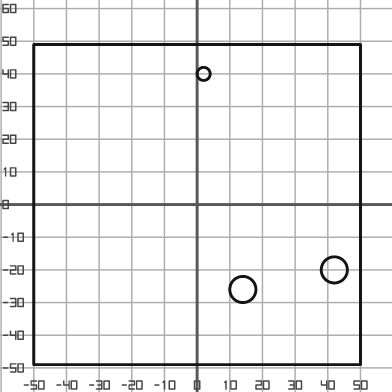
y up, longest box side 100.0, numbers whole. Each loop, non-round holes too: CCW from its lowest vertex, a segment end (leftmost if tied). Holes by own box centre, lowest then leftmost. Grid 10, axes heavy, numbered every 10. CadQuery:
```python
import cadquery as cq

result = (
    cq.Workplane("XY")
    .moveTo(-50.0, -49.0)
    .lineTo(50.0, -49.0)
    .lineTo(50.0, 49.0)
    .lineTo(-50.0, 49.0)
    .close()
    .moveTo(14.0, -26.0)
    .circle(4.0)
    .moveTo(42.0, -20.0)
    .circle(4.0)
    .moveTo(2.0, 40.0)
    .circle(2.0)
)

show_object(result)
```